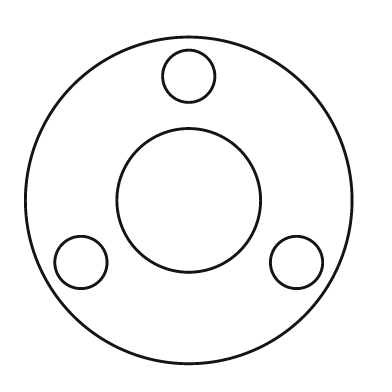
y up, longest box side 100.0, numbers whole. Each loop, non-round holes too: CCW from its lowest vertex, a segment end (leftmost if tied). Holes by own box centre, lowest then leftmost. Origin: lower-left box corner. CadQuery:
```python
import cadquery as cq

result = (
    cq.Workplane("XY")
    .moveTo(50.0, 50.0)
    .circle(50.0)
    .moveTo(17.0, 31.0)
    .circle(8.0)
    .moveTo(83.0, 31.0)
    .circle(8.0)
    .moveTo(50.0, 50.0)
    .circle(22.0)
    .moveTo(50.0, 88.0)
    .circle(8.0)
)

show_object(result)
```